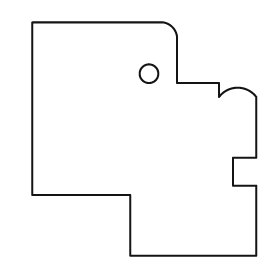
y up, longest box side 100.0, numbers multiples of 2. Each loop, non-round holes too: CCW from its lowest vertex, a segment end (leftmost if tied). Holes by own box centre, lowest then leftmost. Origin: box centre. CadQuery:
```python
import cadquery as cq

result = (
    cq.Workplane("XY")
    .moveTo(-6.0, -50.0)
    .lineTo(48.0, -50.0)
    .lineTo(48.0, -20.0)
    .lineTo(38.0, -20.0)
    .lineTo(38.0, -8.0)
    .lineTo(48.0, -8.0)
    .lineTo(48.0, 18.0)
    .threePointArc((40.0, 22.0), (32.0, 18.0))
    .lineTo(32.0, 24.0)
    .lineTo(14.0, 24.0)
    .lineTo(14.0, 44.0)
    .threePointArc((12.0, 48.0), (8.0, 50.0))
    .lineTo(-48.0, 50.0)
    .lineTo(-48.0, -24.0)
    .lineTo(-6.0, -24.0)
    .close()
    .moveTo(2.0, 28.0)
    .circle(4.0)
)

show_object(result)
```